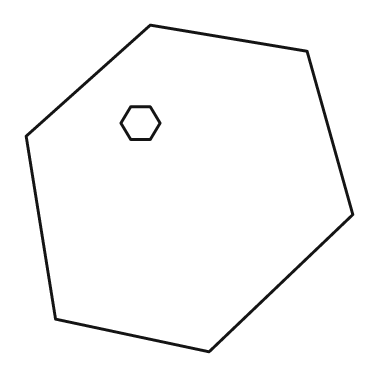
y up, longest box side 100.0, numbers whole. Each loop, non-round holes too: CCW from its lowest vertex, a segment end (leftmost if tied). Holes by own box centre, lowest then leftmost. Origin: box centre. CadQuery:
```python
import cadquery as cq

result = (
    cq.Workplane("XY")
    .moveTo(6.0, -50.0)
    .lineTo(50.0, -8.0)
    .lineTo(36.0, 42.0)
    .lineTo(-12.0, 50.0)
    .lineTo(-50.0, 16.0)
    .lineTo(-41.0, -40.0)
    .close()
    .moveTo(-18.0, 15.0)
    .lineTo(-12.0, 15.0)
    .lineTo(-9.0, 20.0)
    .lineTo(-12.0, 25.0)
    .lineTo(-18.0, 25.0)
    .lineTo(-21.0, 20.0)
    .close()
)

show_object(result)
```